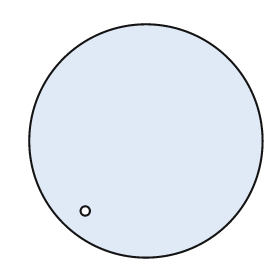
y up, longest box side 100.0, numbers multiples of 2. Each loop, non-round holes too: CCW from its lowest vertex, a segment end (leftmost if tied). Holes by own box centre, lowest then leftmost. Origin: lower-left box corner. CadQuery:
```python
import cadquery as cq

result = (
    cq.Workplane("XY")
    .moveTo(50.0, 50.0)
    .circle(50.0)
    .moveTo(24.0, 20.0)
    .circle(2.0)
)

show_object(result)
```